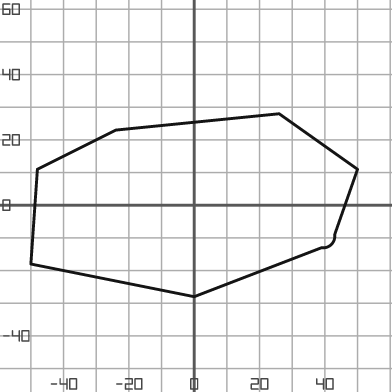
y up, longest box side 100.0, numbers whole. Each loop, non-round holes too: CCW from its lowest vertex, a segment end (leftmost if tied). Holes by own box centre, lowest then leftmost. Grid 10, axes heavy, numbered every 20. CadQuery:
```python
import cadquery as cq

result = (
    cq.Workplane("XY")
    .moveTo(0.0, -28.0)
    .lineTo(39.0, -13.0)
    .threePointArc((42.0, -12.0), (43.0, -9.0))
    .lineTo(50.0, 11.0)
    .lineTo(26.0, 28.0)
    .lineTo(-24.0, 23.0)
    .lineTo(-48.0, 11.0)
    .lineTo(-50.0, -18.0)
    .close()
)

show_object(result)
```